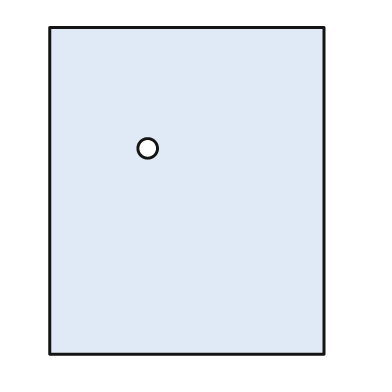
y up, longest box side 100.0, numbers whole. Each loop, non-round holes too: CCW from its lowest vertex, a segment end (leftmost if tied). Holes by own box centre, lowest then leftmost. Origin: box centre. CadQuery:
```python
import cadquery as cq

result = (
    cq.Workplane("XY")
    .moveTo(-42.0, -50.0)
    .lineTo(42.0, -50.0)
    .lineTo(42.0, 50.0)
    .lineTo(-42.0, 50.0)
    .close()
    .moveTo(-12.0, 13.0)
    .circle(3.0)
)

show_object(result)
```